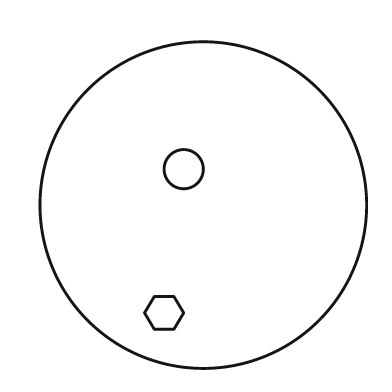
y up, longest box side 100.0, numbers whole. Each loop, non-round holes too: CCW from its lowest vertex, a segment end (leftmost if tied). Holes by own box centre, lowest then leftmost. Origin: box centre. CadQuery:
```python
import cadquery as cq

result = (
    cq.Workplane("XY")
    .moveTo(0.0, 0.0)
    .circle(50.0)
    .moveTo(-15.0, -38.0)
    .lineTo(-9.0, -38.0)
    .lineTo(-6.0, -33.0)
    .lineTo(-9.0, -28.0)
    .lineTo(-15.0, -28.0)
    .lineTo(-18.0, -33.0)
    .close()
    .moveTo(-6.0, 11.0)
    .circle(6.0)
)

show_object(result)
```